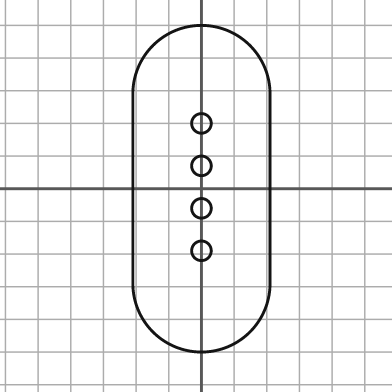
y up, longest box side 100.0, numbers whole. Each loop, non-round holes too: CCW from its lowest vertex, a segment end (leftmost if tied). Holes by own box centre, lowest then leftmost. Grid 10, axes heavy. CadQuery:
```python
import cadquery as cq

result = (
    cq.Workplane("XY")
    .moveTo(-21.0, -29.0)
    .threePointArc((0.0, -50.0), (21.0, -29.0))
    .lineTo(21.0, 29.0)
    .threePointArc((0.0, 50.0), (-21.0, 29.0))
    .close()
    .moveTo(0.0, -19.0)
    .circle(3.0)
    .moveTo(0.0, -6.0)
    .circle(3.0)
    .moveTo(0.0, 7.0)
    .circle(3.0)
    .moveTo(0.0, 20.0)
    .circle(3.0)
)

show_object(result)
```